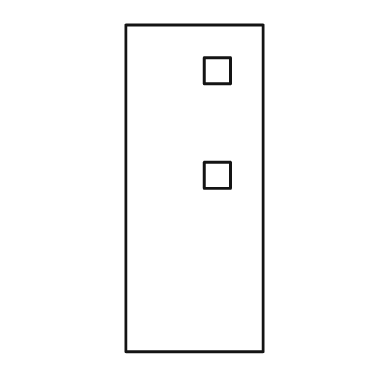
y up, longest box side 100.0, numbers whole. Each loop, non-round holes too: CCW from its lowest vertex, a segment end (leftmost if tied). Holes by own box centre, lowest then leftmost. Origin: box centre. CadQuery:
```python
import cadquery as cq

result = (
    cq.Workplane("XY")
    .moveTo(-21.0, -50.0)
    .lineTo(21.0, -50.0)
    .lineTo(21.0, 50.0)
    .lineTo(-21.0, 50.0)
    .close()
    .moveTo(3.0, 0.0)
    .lineTo(11.0, 0.0)
    .lineTo(11.0, 8.0)
    .lineTo(3.0, 8.0)
    .close()
    .moveTo(3.0, 32.0)
    .lineTo(11.0, 32.0)
    .lineTo(11.0, 40.0)
    .lineTo(3.0, 40.0)
    .close()
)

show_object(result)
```